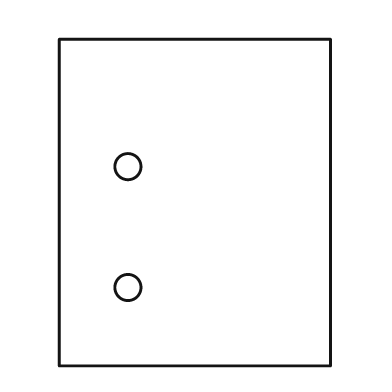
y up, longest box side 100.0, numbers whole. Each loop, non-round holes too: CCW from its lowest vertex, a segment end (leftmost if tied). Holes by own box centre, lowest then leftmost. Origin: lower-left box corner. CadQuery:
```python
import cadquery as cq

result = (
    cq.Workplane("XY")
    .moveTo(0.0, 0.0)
    .lineTo(83.0, 0.0)
    .lineTo(83.0, 100.0)
    .lineTo(0.0, 100.0)
    .close()
    .moveTo(21.0, 24.0)
    .circle(4.0)
    .moveTo(21.0, 61.0)
    .circle(4.0)
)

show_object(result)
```